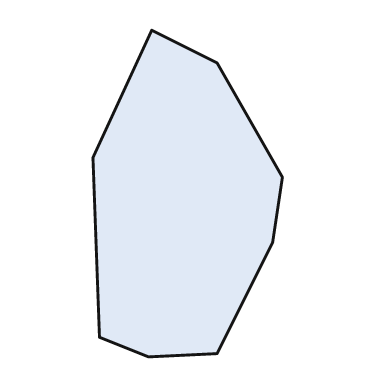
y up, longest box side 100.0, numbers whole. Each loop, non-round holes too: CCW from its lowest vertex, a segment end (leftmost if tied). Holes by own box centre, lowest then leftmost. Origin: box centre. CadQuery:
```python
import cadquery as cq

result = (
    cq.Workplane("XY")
    .moveTo(-12.0, -50.0)
    .lineTo(9.0, -49.0)
    .lineTo(26.0, -15.0)
    .lineTo(29.0, 5.0)
    .lineTo(9.0, 40.0)
    .lineTo(-11.0, 50.0)
    .lineTo(-29.0, 11.0)
    .lineTo(-27.0, -44.0)
    .close()
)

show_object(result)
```